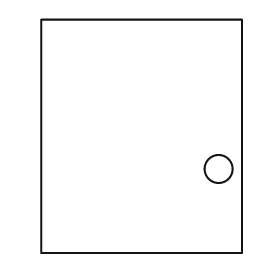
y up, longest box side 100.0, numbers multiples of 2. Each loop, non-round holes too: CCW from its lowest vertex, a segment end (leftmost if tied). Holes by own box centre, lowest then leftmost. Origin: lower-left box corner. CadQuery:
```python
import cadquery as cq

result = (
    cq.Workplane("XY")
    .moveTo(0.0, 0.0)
    .lineTo(86.0, 0.0)
    .lineTo(86.0, 100.0)
    .lineTo(0.0, 100.0)
    .close()
    .moveTo(76.0, 36.0)
    .circle(6.0)
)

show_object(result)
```